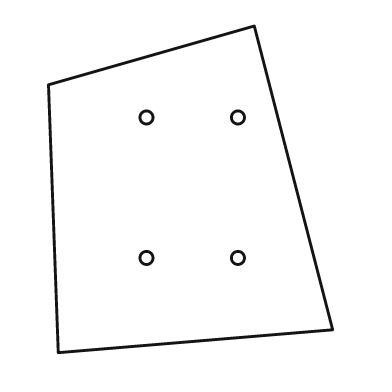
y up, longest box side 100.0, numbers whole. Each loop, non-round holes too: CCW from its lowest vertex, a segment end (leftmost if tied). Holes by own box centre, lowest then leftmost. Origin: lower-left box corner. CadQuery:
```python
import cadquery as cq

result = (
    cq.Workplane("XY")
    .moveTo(3.0, 0.0)
    .lineTo(87.0, 7.0)
    .lineTo(63.0, 100.0)
    .lineTo(0.0, 82.0)
    .close()
    .moveTo(30.0, 29.0)
    .circle(2.0)
    .moveTo(58.0, 29.0)
    .circle(2.0)
    .moveTo(30.0, 72.0)
    .circle(2.0)
    .moveTo(58.0, 72.0)
    .circle(2.0)
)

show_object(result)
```